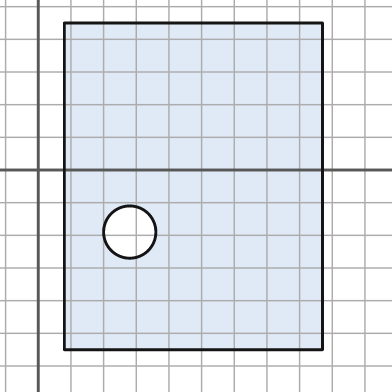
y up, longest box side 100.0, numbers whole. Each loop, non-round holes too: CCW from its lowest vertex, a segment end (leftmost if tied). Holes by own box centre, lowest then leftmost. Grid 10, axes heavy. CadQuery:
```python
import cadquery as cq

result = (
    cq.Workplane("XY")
    .moveTo(8.0, -55.0)
    .lineTo(87.0, -55.0)
    .lineTo(87.0, 45.0)
    .lineTo(8.0, 45.0)
    .close()
    .moveTo(28.0, -19.0)
    .circle(8.0)
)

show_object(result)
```